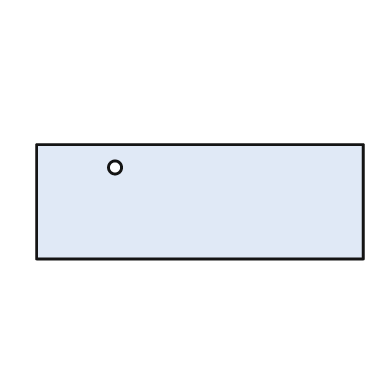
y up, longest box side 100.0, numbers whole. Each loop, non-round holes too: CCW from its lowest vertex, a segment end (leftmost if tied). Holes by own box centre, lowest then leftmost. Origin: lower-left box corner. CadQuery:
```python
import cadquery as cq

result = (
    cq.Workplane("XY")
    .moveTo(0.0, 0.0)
    .lineTo(100.0, 0.0)
    .lineTo(100.0, 35.0)
    .lineTo(0.0, 35.0)
    .close()
    .moveTo(24.0, 28.0)
    .circle(2.0)
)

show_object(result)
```